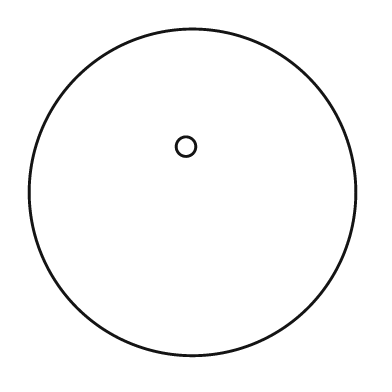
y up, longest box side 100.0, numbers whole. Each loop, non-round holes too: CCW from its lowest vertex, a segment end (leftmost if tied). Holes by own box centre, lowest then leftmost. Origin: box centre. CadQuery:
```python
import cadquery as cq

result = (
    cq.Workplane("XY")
    .moveTo(0.0, 0.0)
    .circle(50.0)
    .moveTo(-2.0, 14.0)
    .circle(3.0)
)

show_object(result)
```